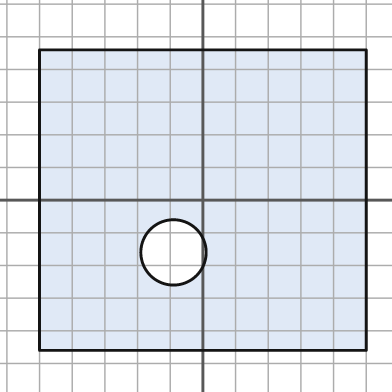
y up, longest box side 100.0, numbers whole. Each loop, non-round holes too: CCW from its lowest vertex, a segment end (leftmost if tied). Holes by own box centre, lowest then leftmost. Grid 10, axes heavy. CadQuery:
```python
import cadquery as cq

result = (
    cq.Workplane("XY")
    .moveTo(-50.0, -46.0)
    .lineTo(50.0, -46.0)
    .lineTo(50.0, 46.0)
    .lineTo(-50.0, 46.0)
    .close()
    .moveTo(-9.0, -16.0)
    .circle(10.0)
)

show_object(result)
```